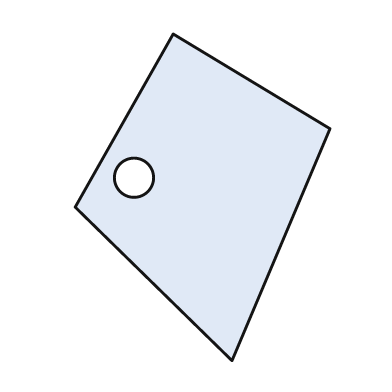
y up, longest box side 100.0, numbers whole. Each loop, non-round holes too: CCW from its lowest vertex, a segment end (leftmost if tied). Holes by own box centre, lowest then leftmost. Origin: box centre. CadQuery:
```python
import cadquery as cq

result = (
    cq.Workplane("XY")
    .moveTo(9.0, -50.0)
    .lineTo(39.0, 21.0)
    .lineTo(-9.0, 50.0)
    .lineTo(-39.0, -3.0)
    .close()
    .moveTo(-21.0, 6.0)
    .circle(6.0)
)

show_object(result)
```